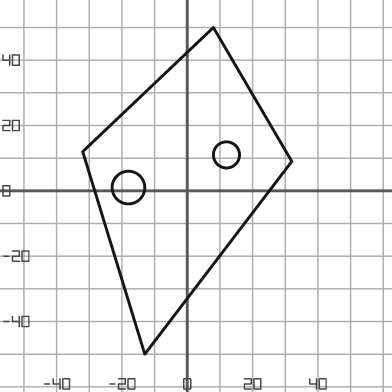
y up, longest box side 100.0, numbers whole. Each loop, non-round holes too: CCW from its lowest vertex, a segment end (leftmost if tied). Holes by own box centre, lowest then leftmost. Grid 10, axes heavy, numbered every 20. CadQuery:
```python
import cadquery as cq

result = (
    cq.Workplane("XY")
    .moveTo(-13.0, -50.0)
    .lineTo(32.0, 9.0)
    .lineTo(8.0, 50.0)
    .lineTo(-32.0, 12.0)
    .close()
    .moveTo(-18.0, 1.0)
    .circle(5.0)
    .moveTo(12.0, 11.0)
    .circle(4.0)
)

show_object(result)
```